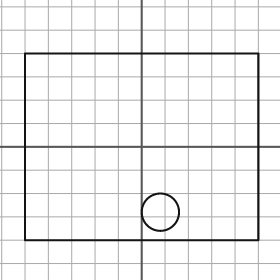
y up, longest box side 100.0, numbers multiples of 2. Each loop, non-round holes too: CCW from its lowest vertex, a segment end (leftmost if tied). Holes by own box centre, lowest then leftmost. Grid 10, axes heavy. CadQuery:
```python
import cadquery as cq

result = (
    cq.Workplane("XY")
    .moveTo(-50.0, -40.0)
    .lineTo(50.0, -40.0)
    .lineTo(50.0, 40.0)
    .lineTo(-50.0, 40.0)
    .close()
    .moveTo(8.0, -28.0)
    .circle(8.0)
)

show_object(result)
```